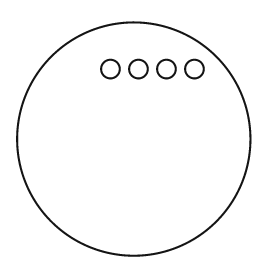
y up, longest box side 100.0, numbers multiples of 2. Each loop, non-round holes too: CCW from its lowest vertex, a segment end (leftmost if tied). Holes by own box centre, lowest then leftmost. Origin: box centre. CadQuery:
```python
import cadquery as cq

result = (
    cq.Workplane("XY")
    .moveTo(0.0, 0.0)
    .circle(50.0)
    .moveTo(-10.0, 30.0)
    .circle(4.0)
    .moveTo(2.0, 30.0)
    .circle(4.0)
    .moveTo(14.0, 30.0)
    .circle(4.0)
    .moveTo(26.0, 30.0)
    .circle(4.0)
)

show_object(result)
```